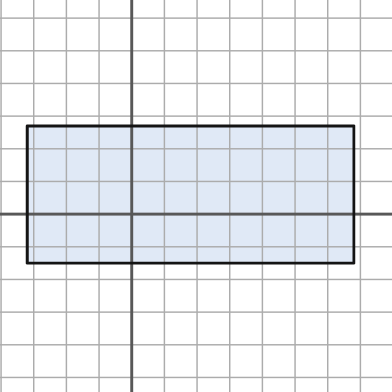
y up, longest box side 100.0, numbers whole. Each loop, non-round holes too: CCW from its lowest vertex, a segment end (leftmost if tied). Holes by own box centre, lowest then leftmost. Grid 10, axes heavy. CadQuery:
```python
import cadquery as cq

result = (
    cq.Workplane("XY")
    .moveTo(-32.0, -15.0)
    .lineTo(68.0, -15.0)
    .lineTo(68.0, 27.0)
    .lineTo(-32.0, 27.0)
    .close()
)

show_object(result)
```